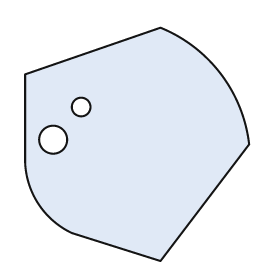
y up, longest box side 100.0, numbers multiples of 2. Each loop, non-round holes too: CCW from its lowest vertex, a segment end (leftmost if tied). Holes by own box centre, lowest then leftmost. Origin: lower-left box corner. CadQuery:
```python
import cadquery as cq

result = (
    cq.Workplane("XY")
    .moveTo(58.0, 0.0)
    .lineTo(96.0, 50.0)
    .threePointArc((84.0, 80.0), (58.0, 100.0))
    .lineTo(0.0, 80.0)
    .lineTo(0.0, 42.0)
    .threePointArc((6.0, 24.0), (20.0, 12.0))
    .close()
    .moveTo(12.0, 52.0)
    .circle(6.0)
    .moveTo(24.0, 66.0)
    .circle(4.0)
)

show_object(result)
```